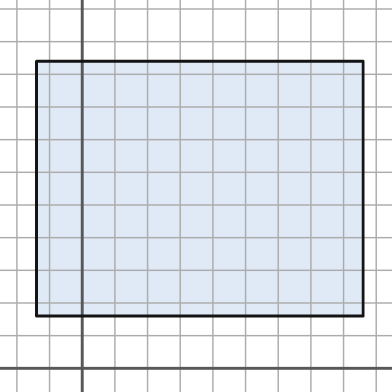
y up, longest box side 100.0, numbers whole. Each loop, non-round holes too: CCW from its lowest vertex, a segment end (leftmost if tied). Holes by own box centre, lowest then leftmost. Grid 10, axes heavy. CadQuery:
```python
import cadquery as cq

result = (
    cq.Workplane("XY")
    .moveTo(-14.0, 16.0)
    .lineTo(86.0, 16.0)
    .lineTo(86.0, 94.0)
    .lineTo(-14.0, 94.0)
    .close()
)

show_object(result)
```